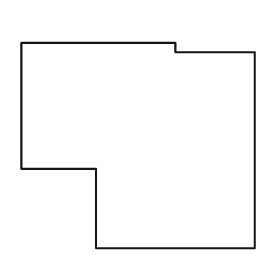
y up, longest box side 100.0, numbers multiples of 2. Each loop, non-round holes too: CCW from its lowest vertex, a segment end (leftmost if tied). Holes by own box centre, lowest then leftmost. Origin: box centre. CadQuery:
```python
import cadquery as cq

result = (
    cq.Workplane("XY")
    .moveTo(-18.0, -44.0)
    .lineTo(50.0, -44.0)
    .lineTo(50.0, 40.0)
    .lineTo(16.0, 40.0)
    .lineTo(16.0, 44.0)
    .lineTo(-50.0, 44.0)
    .lineTo(-50.0, -10.0)
    .lineTo(-18.0, -10.0)
    .close()
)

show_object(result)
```